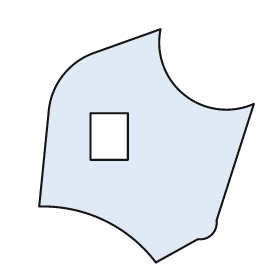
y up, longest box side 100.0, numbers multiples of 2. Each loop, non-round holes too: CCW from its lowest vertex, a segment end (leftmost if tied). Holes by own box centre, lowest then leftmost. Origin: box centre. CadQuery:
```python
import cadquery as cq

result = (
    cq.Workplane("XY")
    .moveTo(4.0, -50.0)
    .lineTo(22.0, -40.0)
    .threePointArc((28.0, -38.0), (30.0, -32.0))
    .lineTo(46.0, 18.0)
    .threePointArc((16.0, 22.0), (6.0, 50.0))
    .lineTo(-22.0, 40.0)
    .threePointArc((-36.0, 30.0), (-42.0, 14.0))
    .lineTo(-46.0, -26.0)
    .threePointArc((-18.0, -32.0), (4.0, -50.0))
    .close()
    .moveTo(-24.0, -6.0)
    .lineTo(-8.0, -6.0)
    .lineTo(-8.0, 14.0)
    .lineTo(-24.0, 14.0)
    .close()
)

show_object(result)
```